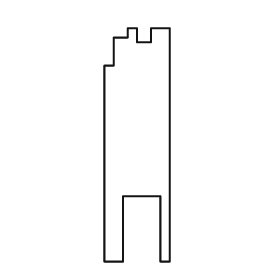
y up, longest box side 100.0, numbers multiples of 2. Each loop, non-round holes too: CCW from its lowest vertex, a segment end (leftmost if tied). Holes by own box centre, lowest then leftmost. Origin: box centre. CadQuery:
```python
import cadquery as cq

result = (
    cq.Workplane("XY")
    .moveTo(-14.0, -50.0)
    .lineTo(-6.0, -50.0)
    .lineTo(-6.0, -22.0)
    .lineTo(10.0, -22.0)
    .lineTo(10.0, -50.0)
    .lineTo(14.0, -50.0)
    .lineTo(14.0, 50.0)
    .lineTo(6.0, 50.0)
    .lineTo(6.0, 44.0)
    .lineTo(0.0, 44.0)
    .lineTo(0.0, 50.0)
    .lineTo(-4.0, 50.0)
    .lineTo(-4.0, 46.0)
    .lineTo(-10.0, 46.0)
    .lineTo(-10.0, 34.0)
    .lineTo(-14.0, 34.0)
    .close()
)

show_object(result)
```